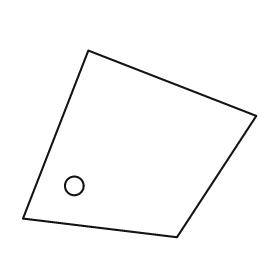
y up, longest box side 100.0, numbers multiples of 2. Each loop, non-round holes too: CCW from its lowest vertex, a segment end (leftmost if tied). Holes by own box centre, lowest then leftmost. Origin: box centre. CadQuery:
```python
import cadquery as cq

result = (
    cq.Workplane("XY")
    .moveTo(16.0, -40.0)
    .lineTo(50.0, 12.0)
    .lineTo(-22.0, 40.0)
    .lineTo(-50.0, -32.0)
    .close()
    .moveTo(-28.0, -18.0)
    .circle(4.0)
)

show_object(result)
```